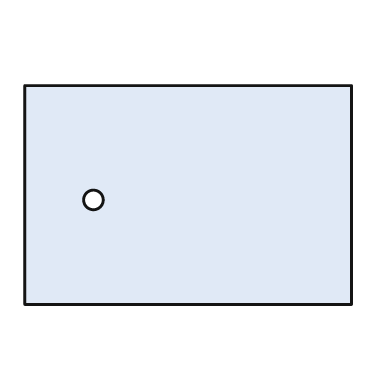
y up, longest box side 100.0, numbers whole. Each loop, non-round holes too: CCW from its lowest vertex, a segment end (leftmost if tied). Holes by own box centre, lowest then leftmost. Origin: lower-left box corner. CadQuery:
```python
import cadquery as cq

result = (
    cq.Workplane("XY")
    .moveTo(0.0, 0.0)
    .lineTo(100.0, 0.0)
    .lineTo(100.0, 67.0)
    .lineTo(0.0, 67.0)
    .close()
    .moveTo(21.0, 32.0)
    .circle(3.0)
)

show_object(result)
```